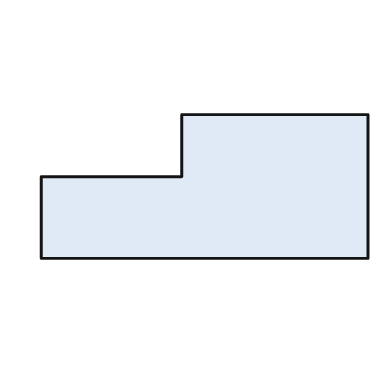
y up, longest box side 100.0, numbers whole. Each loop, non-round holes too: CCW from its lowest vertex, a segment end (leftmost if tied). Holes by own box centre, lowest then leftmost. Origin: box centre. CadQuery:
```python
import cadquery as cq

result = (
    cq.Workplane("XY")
    .moveTo(-50.0, -22.0)
    .lineTo(50.0, -22.0)
    .lineTo(50.0, 22.0)
    .lineTo(-7.0, 22.0)
    .lineTo(-7.0, 3.0)
    .lineTo(-50.0, 3.0)
    .close()
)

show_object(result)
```